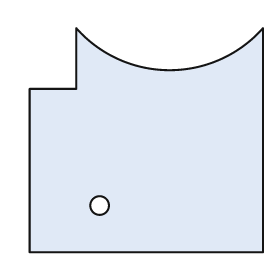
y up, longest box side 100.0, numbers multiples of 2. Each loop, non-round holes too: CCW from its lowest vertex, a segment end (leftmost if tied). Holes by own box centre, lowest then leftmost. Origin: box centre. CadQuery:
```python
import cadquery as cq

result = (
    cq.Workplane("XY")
    .moveTo(-50.0, -48.0)
    .lineTo(50.0, -48.0)
    .lineTo(50.0, 48.0)
    .threePointArc((10.0, 30.0), (-30.0, 48.0))
    .lineTo(-30.0, 22.0)
    .lineTo(-50.0, 22.0)
    .close()
    .moveTo(-20.0, -28.0)
    .circle(4.0)
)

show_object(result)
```